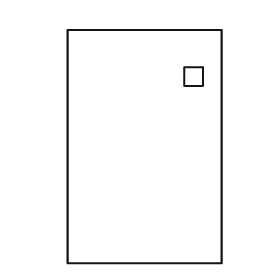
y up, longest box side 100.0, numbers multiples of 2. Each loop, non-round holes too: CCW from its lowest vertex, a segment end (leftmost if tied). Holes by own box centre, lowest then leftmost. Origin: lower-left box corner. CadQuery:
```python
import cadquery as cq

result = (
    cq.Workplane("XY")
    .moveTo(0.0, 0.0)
    .lineTo(66.0, 0.0)
    .lineTo(66.0, 100.0)
    .lineTo(0.0, 100.0)
    .close()
    .moveTo(50.0, 76.0)
    .lineTo(58.0, 76.0)
    .lineTo(58.0, 84.0)
    .lineTo(50.0, 84.0)
    .close()
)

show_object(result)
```